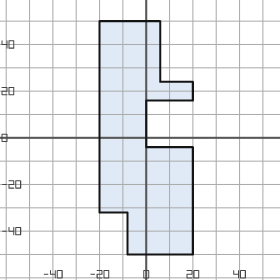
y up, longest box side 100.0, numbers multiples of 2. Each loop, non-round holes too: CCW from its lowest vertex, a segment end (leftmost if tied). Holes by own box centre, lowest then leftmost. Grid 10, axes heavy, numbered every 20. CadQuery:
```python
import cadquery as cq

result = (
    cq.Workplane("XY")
    .moveTo(-8.0, -50.0)
    .lineTo(20.0, -50.0)
    .lineTo(20.0, -4.0)
    .lineTo(0.0, -4.0)
    .lineTo(0.0, 16.0)
    .lineTo(20.0, 16.0)
    .lineTo(20.0, 24.0)
    .lineTo(6.0, 24.0)
    .lineTo(6.0, 50.0)
    .lineTo(-20.0, 50.0)
    .lineTo(-20.0, -32.0)
    .lineTo(-8.0, -32.0)
    .close()
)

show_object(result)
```